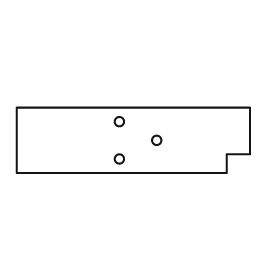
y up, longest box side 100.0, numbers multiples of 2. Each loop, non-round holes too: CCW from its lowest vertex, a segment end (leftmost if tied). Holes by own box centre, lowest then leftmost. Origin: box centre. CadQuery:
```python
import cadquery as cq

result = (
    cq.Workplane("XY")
    .moveTo(-50.0, -14.0)
    .lineTo(40.0, -14.0)
    .lineTo(40.0, -6.0)
    .lineTo(50.0, -6.0)
    .lineTo(50.0, 14.0)
    .lineTo(-50.0, 14.0)
    .close()
    .moveTo(-6.0, -8.0)
    .circle(2.0)
    .moveTo(10.0, 0.0)
    .circle(2.0)
    .moveTo(-6.0, 8.0)
    .circle(2.0)
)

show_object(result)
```